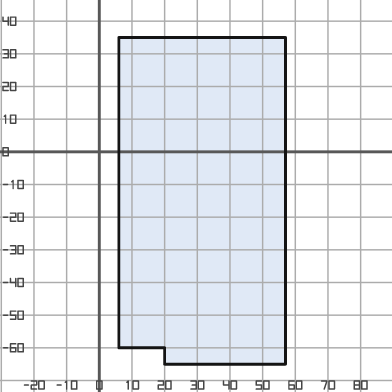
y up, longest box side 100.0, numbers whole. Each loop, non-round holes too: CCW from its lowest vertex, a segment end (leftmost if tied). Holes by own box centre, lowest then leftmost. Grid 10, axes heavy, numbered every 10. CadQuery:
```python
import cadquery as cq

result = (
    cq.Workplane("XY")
    .moveTo(20.0, -65.0)
    .lineTo(57.0, -65.0)
    .lineTo(57.0, 35.0)
    .lineTo(6.0, 35.0)
    .lineTo(6.0, -60.0)
    .lineTo(20.0, -60.0)
    .close()
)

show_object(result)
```